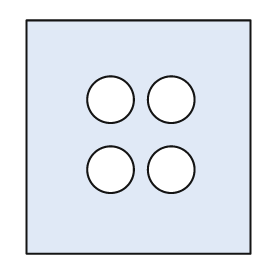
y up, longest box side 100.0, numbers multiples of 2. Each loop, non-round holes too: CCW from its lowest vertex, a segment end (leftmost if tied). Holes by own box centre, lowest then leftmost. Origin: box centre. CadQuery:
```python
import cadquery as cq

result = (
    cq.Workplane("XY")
    .moveTo(-48.0, -50.0)
    .lineTo(48.0, -50.0)
    .lineTo(48.0, 50.0)
    .lineTo(-48.0, 50.0)
    .close()
    .moveTo(-12.0, -14.0)
    .circle(10.0)
    .moveTo(14.0, -14.0)
    .circle(10.0)
    .moveTo(-12.0, 16.0)
    .circle(10.0)
    .moveTo(14.0, 16.0)
    .circle(10.0)
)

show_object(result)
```